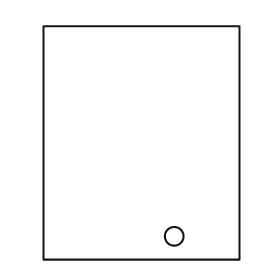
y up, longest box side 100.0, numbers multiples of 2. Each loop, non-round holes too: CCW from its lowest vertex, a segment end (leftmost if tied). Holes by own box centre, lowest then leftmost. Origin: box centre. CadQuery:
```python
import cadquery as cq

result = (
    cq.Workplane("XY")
    .moveTo(-42.0, -50.0)
    .lineTo(42.0, -50.0)
    .lineTo(42.0, 50.0)
    .lineTo(-42.0, 50.0)
    .close()
    .moveTo(14.0, -40.0)
    .circle(4.0)
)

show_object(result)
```